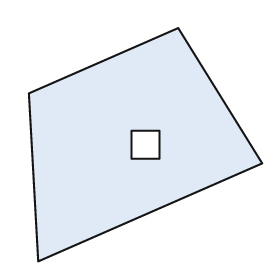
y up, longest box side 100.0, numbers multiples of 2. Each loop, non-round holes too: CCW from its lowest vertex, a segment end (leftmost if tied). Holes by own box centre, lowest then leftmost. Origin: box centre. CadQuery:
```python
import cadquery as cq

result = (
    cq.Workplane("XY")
    .moveTo(-46.0, -50.0)
    .lineTo(50.0, -8.0)
    .lineTo(14.0, 50.0)
    .lineTo(-50.0, 22.0)
    .close()
    .moveTo(-6.0, -6.0)
    .lineTo(6.0, -6.0)
    .lineTo(6.0, 6.0)
    .lineTo(-6.0, 6.0)
    .close()
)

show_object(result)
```